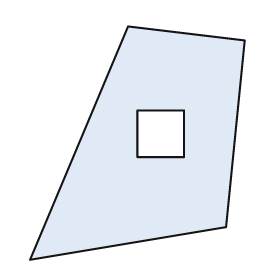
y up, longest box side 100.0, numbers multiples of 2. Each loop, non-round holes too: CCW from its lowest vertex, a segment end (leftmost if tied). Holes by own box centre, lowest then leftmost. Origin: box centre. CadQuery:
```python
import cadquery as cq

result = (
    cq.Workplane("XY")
    .moveTo(-46.0, -50.0)
    .lineTo(38.0, -36.0)
    .lineTo(46.0, 44.0)
    .lineTo(-4.0, 50.0)
    .close()
    .moveTo(0.0, -6.0)
    .lineTo(20.0, -6.0)
    .lineTo(20.0, 14.0)
    .lineTo(0.0, 14.0)
    .close()
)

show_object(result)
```